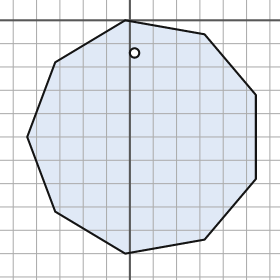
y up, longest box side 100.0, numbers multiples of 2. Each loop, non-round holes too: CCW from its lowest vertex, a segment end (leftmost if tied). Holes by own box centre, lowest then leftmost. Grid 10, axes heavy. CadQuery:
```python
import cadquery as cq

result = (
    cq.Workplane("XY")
    .moveTo(-2.0, -100.0)
    .lineTo(32.0, -94.0)
    .lineTo(54.0, -68.0)
    .lineTo(54.0, -32.0)
    .lineTo(32.0, -6.0)
    .lineTo(-2.0, 0.0)
    .lineTo(-32.0, -18.0)
    .lineTo(-44.0, -50.0)
    .lineTo(-32.0, -82.0)
    .close()
    .moveTo(2.0, -14.0)
    .circle(2.0)
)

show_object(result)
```